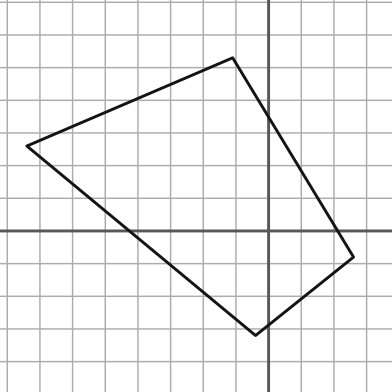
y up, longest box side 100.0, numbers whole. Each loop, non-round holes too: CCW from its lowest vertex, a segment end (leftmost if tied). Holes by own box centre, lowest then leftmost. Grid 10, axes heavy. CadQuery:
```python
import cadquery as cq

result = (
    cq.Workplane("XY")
    .moveTo(-4.0, -32.0)
    .lineTo(26.0, -8.0)
    .lineTo(-11.0, 53.0)
    .lineTo(-74.0, 26.0)
    .close()
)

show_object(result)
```